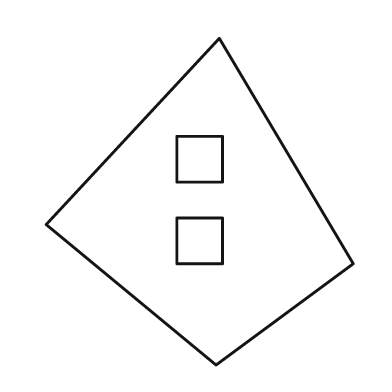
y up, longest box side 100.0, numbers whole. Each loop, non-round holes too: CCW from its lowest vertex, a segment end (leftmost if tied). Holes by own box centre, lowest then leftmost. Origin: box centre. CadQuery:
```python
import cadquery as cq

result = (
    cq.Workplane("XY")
    .moveTo(5.0, -50.0)
    .lineTo(47.0, -19.0)
    .lineTo(6.0, 50.0)
    .lineTo(-47.0, -7.0)
    .close()
    .moveTo(-7.0, -19.0)
    .lineTo(7.0, -19.0)
    .lineTo(7.0, -5.0)
    .lineTo(-7.0, -5.0)
    .close()
    .moveTo(-7.0, 6.0)
    .lineTo(7.0, 6.0)
    .lineTo(7.0, 20.0)
    .lineTo(-7.0, 20.0)
    .close()
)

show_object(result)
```